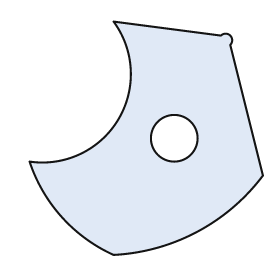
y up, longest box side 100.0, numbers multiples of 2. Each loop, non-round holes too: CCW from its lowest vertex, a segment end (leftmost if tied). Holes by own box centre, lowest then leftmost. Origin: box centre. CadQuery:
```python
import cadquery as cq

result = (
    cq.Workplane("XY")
    .moveTo(-14.0, -50.0)
    .threePointArc((22.0, -40.0), (50.0, -16.0))
    .lineTo(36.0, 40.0)
    .threePointArc((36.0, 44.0), (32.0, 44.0))
    .lineTo(-14.0, 50.0)
    .threePointArc((-12.0, 8.0), (-50.0, -10.0))
    .threePointArc((-36.0, -34.0), (-14.0, -50.0))
    .close()
    .moveTo(12.0, 0.0)
    .circle(10.0)
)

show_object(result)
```